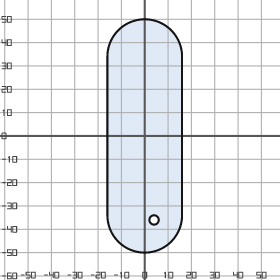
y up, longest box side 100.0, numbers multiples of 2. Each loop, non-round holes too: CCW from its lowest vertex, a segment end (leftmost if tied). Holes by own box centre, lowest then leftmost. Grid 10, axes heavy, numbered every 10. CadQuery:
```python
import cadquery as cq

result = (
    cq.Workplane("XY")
    .moveTo(-16.0, -34.0)
    .threePointArc((0.0, -50.0), (16.0, -34.0))
    .lineTo(16.0, 34.0)
    .threePointArc((0.0, 50.0), (-16.0, 34.0))
    .close()
    .moveTo(4.0, -36.0)
    .circle(2.0)
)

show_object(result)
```